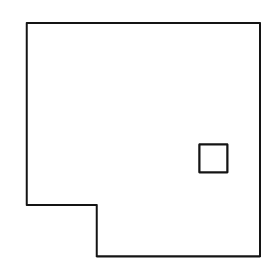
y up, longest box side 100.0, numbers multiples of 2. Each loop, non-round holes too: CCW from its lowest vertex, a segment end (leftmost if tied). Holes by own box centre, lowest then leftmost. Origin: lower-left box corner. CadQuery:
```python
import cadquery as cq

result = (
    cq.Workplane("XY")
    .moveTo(30.0, 0.0)
    .lineTo(100.0, 0.0)
    .lineTo(100.0, 100.0)
    .lineTo(0.0, 100.0)
    .lineTo(0.0, 22.0)
    .lineTo(30.0, 22.0)
    .close()
    .moveTo(74.0, 36.0)
    .lineTo(86.0, 36.0)
    .lineTo(86.0, 48.0)
    .lineTo(74.0, 48.0)
    .close()
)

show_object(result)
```